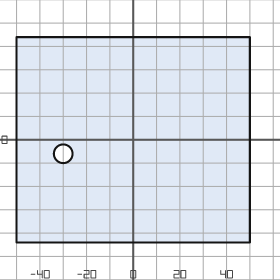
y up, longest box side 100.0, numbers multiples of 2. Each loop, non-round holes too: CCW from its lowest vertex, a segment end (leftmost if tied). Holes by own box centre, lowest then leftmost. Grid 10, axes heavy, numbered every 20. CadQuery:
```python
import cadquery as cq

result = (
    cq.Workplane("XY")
    .moveTo(-50.0, -44.0)
    .lineTo(50.0, -44.0)
    .lineTo(50.0, 44.0)
    .lineTo(-50.0, 44.0)
    .close()
    .moveTo(-30.0, -6.0)
    .circle(4.0)
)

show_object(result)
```